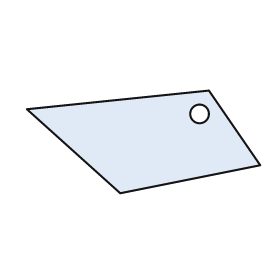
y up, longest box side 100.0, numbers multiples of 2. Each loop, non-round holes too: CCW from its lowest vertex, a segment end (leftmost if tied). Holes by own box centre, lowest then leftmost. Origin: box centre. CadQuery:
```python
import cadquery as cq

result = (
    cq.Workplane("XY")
    .moveTo(-10.0, -22.0)
    .lineTo(50.0, -10.0)
    .lineTo(28.0, 22.0)
    .lineTo(-50.0, 14.0)
    .close()
    .moveTo(24.0, 12.0)
    .circle(4.0)
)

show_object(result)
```